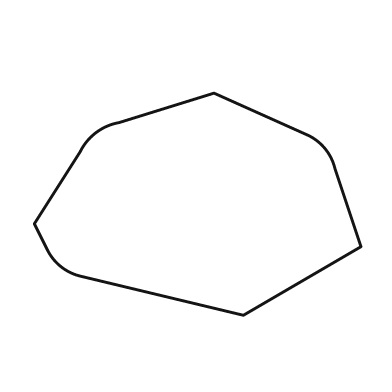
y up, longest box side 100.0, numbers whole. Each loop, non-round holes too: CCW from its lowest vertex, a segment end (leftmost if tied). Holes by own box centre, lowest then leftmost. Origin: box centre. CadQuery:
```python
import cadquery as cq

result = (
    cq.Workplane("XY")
    .moveTo(14.0, -34.0)
    .lineTo(50.0, -13.0)
    .lineTo(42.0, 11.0)
    .threePointArc((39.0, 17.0), (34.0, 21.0))
    .lineTo(5.0, 34.0)
    .lineTo(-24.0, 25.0)
    .threePointArc((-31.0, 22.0), (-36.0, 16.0))
    .lineTo(-50.0, -6.0)
    .lineTo(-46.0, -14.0)
    .threePointArc((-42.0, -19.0), (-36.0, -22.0))
    .close()
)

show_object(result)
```